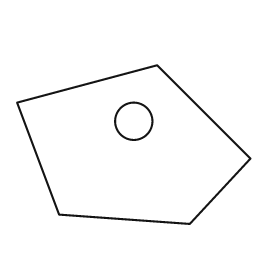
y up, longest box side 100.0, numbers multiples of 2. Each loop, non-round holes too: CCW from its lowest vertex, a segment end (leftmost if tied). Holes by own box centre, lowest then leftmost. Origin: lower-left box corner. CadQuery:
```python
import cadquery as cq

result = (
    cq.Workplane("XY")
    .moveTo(74.0, 0.0)
    .lineTo(100.0, 28.0)
    .lineTo(60.0, 68.0)
    .lineTo(0.0, 52.0)
    .lineTo(18.0, 4.0)
    .close()
    .moveTo(50.0, 44.0)
    .circle(8.0)
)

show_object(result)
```